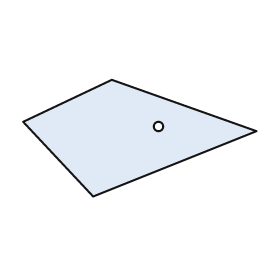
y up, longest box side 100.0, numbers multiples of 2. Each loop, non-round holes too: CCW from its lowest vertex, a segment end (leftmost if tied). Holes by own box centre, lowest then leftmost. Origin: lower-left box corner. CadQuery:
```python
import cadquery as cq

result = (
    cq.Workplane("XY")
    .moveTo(30.0, 0.0)
    .lineTo(100.0, 28.0)
    .lineTo(38.0, 50.0)
    .lineTo(0.0, 32.0)
    .close()
    .moveTo(58.0, 30.0)
    .circle(2.0)
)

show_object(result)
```